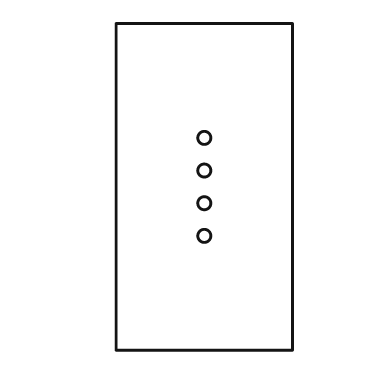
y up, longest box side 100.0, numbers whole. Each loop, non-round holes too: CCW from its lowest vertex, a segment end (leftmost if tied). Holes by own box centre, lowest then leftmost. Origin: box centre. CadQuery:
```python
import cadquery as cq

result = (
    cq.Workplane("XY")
    .moveTo(-27.0, -50.0)
    .lineTo(27.0, -50.0)
    .lineTo(27.0, 50.0)
    .lineTo(-27.0, 50.0)
    .close()
    .moveTo(0.0, -15.0)
    .circle(2.0)
    .moveTo(0.0, -5.0)
    .circle(2.0)
    .moveTo(0.0, 5.0)
    .circle(2.0)
    .moveTo(0.0, 15.0)
    .circle(2.0)
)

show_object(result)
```